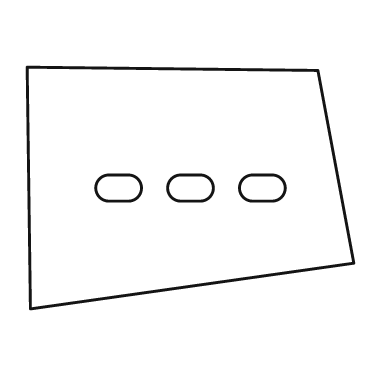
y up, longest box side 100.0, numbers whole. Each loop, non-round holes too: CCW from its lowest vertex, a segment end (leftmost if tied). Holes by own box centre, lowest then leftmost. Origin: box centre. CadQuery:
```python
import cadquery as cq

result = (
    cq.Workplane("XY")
    .moveTo(-49.0, -37.0)
    .lineTo(50.0, -23.0)
    .lineTo(39.0, 36.0)
    .lineTo(-50.0, 37.0)
    .close()
    .moveTo(-25.0, -4.0)
    .lineTo(-19.0, -4.0)
    .threePointArc((-15.0, 0.0), (-19.0, 4.0))
    .lineTo(-25.0, 4.0)
    .threePointArc((-29.0, 0.0), (-25.0, -4.0))
    .close()
    .moveTo(-3.0, -4.0)
    .lineTo(3.0, -4.0)
    .threePointArc((7.0, 0.0), (3.0, 4.0))
    .lineTo(-3.0, 4.0)
    .threePointArc((-7.0, 0.0), (-3.0, -4.0))
    .close()
    .moveTo(19.0, -4.0)
    .lineTo(25.0, -4.0)
    .threePointArc((29.0, 0.0), (25.0, 4.0))
    .lineTo(19.0, 4.0)
    .threePointArc((15.0, 0.0), (19.0, -4.0))
    .close()
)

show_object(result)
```